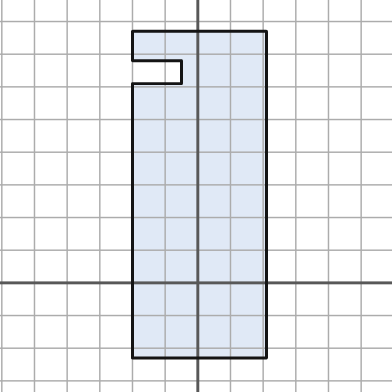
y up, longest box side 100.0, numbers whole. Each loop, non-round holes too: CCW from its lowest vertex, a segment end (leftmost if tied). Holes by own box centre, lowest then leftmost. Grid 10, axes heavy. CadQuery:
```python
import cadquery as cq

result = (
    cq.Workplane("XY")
    .moveTo(-20.0, -23.0)
    .lineTo(21.0, -23.0)
    .lineTo(21.0, 77.0)
    .lineTo(-20.0, 77.0)
    .lineTo(-20.0, 68.0)
    .lineTo(-5.0, 68.0)
    .lineTo(-5.0, 61.0)
    .lineTo(-20.0, 61.0)
    .close()
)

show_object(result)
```